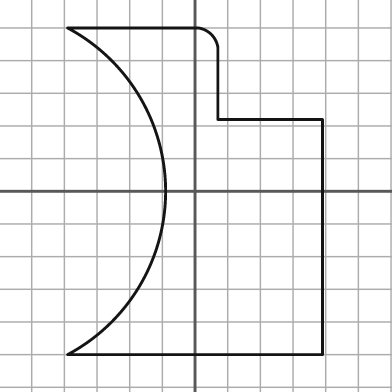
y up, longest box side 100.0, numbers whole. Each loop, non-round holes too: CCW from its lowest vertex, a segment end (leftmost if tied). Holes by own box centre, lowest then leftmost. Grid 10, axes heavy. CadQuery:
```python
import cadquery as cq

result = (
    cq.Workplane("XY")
    .moveTo(-39.0, -50.0)
    .lineTo(39.0, -50.0)
    .lineTo(39.0, 22.0)
    .lineTo(7.0, 22.0)
    .lineTo(7.0, 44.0)
    .threePointArc((5.0, 48.0), (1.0, 50.0))
    .lineTo(-39.0, 50.0)
    .threePointArc((-9.0, 0.0), (-39.0, -50.0))
    .close()
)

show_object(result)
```